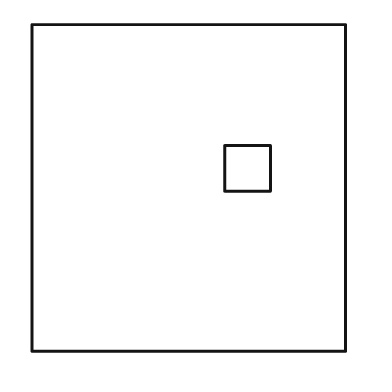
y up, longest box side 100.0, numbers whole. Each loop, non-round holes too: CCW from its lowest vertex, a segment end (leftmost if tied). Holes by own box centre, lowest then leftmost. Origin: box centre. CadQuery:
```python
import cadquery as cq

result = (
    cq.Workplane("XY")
    .moveTo(-48.0, -50.0)
    .lineTo(48.0, -50.0)
    .lineTo(48.0, 50.0)
    .lineTo(-48.0, 50.0)
    .close()
    .moveTo(11.0, -1.0)
    .lineTo(25.0, -1.0)
    .lineTo(25.0, 13.0)
    .lineTo(11.0, 13.0)
    .close()
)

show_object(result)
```